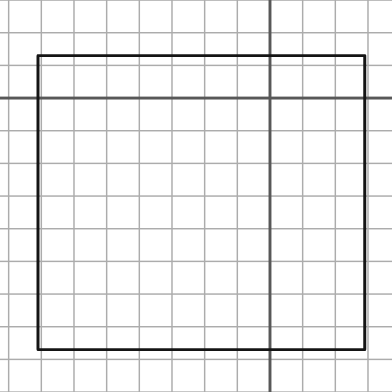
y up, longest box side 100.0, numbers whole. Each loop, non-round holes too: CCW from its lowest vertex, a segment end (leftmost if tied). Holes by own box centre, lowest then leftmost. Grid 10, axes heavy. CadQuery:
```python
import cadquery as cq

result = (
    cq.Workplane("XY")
    .moveTo(-71.0, -77.0)
    .lineTo(29.0, -77.0)
    .lineTo(29.0, 13.0)
    .lineTo(-71.0, 13.0)
    .close()
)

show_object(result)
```